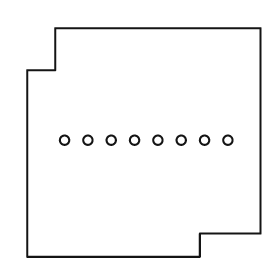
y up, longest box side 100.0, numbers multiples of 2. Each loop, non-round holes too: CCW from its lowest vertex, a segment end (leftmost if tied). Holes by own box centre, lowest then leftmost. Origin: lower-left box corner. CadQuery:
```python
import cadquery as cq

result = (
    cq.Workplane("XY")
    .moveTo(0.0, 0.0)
    .lineTo(74.0, 0.0)
    .lineTo(74.0, 10.0)
    .lineTo(100.0, 10.0)
    .lineTo(100.0, 98.0)
    .lineTo(12.0, 98.0)
    .lineTo(12.0, 80.0)
    .lineTo(0.0, 80.0)
    .close()
    .moveTo(16.0, 50.0)
    .circle(2.0)
    .moveTo(26.0, 50.0)
    .circle(2.0)
    .moveTo(36.0, 50.0)
    .circle(2.0)
    .moveTo(46.0, 50.0)
    .circle(2.0)
    .moveTo(56.0, 50.0)
    .circle(2.0)
    .moveTo(66.0, 50.0)
    .circle(2.0)
    .moveTo(76.0, 50.0)
    .circle(2.0)
    .moveTo(86.0, 50.0)
    .circle(2.0)
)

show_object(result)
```